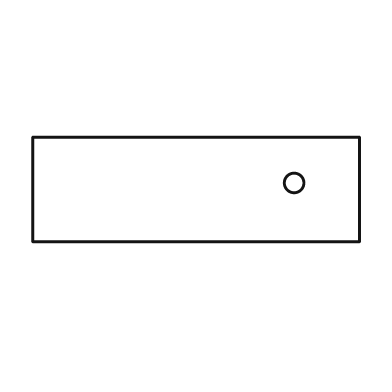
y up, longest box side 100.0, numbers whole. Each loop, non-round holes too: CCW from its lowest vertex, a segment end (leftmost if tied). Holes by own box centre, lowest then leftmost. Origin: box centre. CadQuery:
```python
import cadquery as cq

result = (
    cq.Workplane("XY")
    .moveTo(-50.0, -16.0)
    .lineTo(50.0, -16.0)
    .lineTo(50.0, 16.0)
    .lineTo(-50.0, 16.0)
    .close()
    .moveTo(30.0, 2.0)
    .circle(3.0)
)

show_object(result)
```